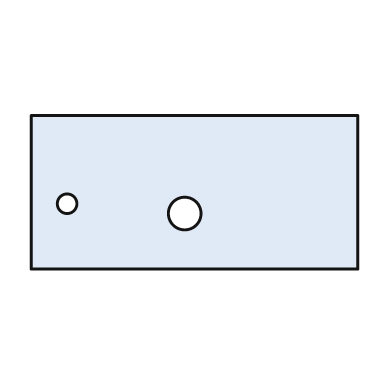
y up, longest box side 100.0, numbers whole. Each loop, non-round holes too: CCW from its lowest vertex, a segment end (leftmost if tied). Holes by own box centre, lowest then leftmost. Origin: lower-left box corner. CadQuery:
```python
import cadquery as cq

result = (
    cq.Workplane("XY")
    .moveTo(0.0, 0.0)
    .lineTo(100.0, 0.0)
    .lineTo(100.0, 47.0)
    .lineTo(0.0, 47.0)
    .close()
    .moveTo(47.0, 17.0)
    .circle(5.0)
    .moveTo(11.0, 20.0)
    .circle(3.0)
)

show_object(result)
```